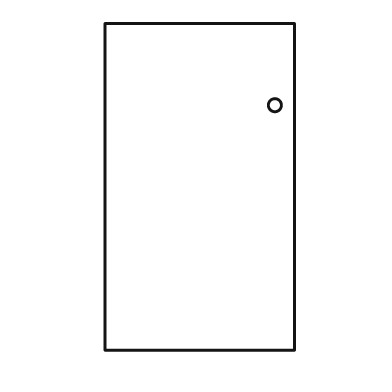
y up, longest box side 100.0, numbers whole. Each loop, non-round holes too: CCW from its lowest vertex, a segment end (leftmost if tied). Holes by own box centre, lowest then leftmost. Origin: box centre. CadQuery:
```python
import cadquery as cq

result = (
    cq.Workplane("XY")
    .moveTo(-29.0, -50.0)
    .lineTo(29.0, -50.0)
    .lineTo(29.0, 50.0)
    .lineTo(-29.0, 50.0)
    .close()
    .moveTo(23.0, 25.0)
    .circle(2.0)
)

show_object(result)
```